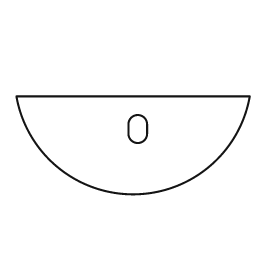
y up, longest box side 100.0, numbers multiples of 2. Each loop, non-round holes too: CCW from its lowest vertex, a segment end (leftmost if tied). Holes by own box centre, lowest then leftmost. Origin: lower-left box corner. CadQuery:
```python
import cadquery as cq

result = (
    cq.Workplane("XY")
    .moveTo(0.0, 42.0)
    .threePointArc((50.0, 0.0), (100.0, 42.0))
    .close()
    .moveTo(48.0, 26.0)
    .threePointArc((52.0, 22.0), (56.0, 26.0))
    .lineTo(56.0, 30.0)
    .threePointArc((52.0, 34.0), (48.0, 30.0))
    .close()
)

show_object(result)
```